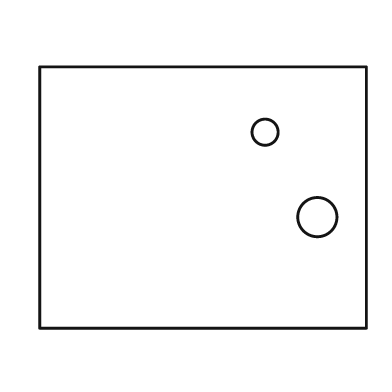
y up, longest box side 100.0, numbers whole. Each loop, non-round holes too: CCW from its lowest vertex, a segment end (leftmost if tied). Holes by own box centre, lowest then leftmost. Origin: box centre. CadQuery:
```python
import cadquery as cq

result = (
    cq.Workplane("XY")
    .moveTo(-50.0, -40.0)
    .lineTo(50.0, -40.0)
    .lineTo(50.0, 40.0)
    .lineTo(-50.0, 40.0)
    .close()
    .moveTo(35.0, -6.0)
    .circle(6.0)
    .moveTo(19.0, 20.0)
    .circle(4.0)
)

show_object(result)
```